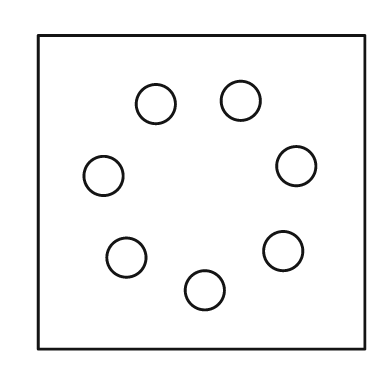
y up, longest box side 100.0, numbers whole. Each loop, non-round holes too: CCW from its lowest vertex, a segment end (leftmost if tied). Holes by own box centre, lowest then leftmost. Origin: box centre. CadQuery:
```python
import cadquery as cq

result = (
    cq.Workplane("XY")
    .moveTo(-50.0, -48.0)
    .lineTo(50.0, -48.0)
    .lineTo(50.0, 48.0)
    .lineTo(-50.0, 48.0)
    .close()
    .moveTo(1.0, -30.0)
    .circle(6.0)
    .moveTo(-23.0, -20.0)
    .circle(6.0)
    .moveTo(25.0, -18.0)
    .circle(6.0)
    .moveTo(-30.0, 5.0)
    .circle(6.0)
    .moveTo(29.0, 8.0)
    .circle(6.0)
    .moveTo(-14.0, 27.0)
    .circle(6.0)
    .moveTo(12.0, 28.0)
    .circle(6.0)
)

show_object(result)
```